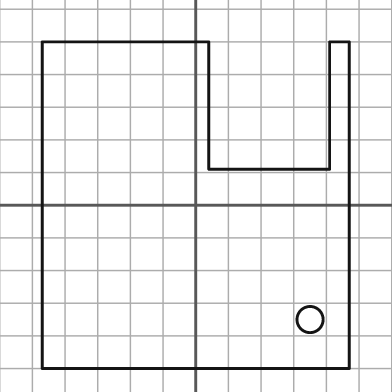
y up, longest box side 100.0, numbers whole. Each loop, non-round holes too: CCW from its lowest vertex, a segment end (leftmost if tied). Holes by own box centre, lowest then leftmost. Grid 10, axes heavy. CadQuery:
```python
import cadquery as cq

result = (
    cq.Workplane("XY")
    .moveTo(-47.0, -50.0)
    .lineTo(47.0, -50.0)
    .lineTo(47.0, 50.0)
    .lineTo(41.0, 50.0)
    .lineTo(41.0, 11.0)
    .lineTo(4.0, 11.0)
    .lineTo(4.0, 50.0)
    .lineTo(-47.0, 50.0)
    .close()
    .moveTo(35.0, -35.0)
    .circle(4.0)
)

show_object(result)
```